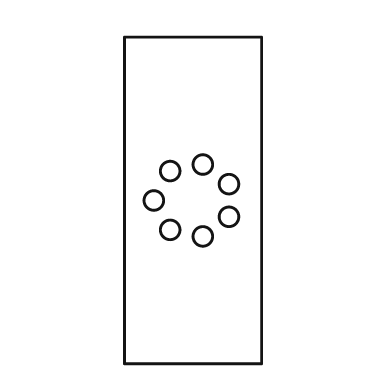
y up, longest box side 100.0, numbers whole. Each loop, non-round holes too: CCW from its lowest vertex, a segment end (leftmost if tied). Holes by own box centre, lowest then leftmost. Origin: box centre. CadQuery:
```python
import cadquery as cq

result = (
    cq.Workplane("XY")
    .moveTo(-21.0, -50.0)
    .lineTo(21.0, -50.0)
    .lineTo(21.0, 50.0)
    .lineTo(-21.0, 50.0)
    .close()
    .moveTo(3.0, -11.0)
    .circle(3.0)
    .moveTo(-7.0, -9.0)
    .circle(3.0)
    .moveTo(11.0, -5.0)
    .circle(3.0)
    .moveTo(-12.0, 0.0)
    .circle(3.0)
    .moveTo(11.0, 5.0)
    .circle(3.0)
    .moveTo(-7.0, 9.0)
    .circle(3.0)
    .moveTo(3.0, 11.0)
    .circle(3.0)
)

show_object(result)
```